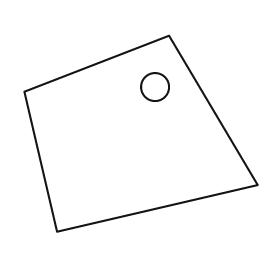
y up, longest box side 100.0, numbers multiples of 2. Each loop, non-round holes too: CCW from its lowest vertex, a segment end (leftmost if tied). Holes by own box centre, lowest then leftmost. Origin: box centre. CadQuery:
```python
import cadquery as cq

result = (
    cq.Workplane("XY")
    .moveTo(-36.0, -42.0)
    .lineTo(50.0, -22.0)
    .lineTo(12.0, 42.0)
    .lineTo(-50.0, 18.0)
    .close()
    .moveTo(6.0, 20.0)
    .circle(6.0)
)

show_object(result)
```